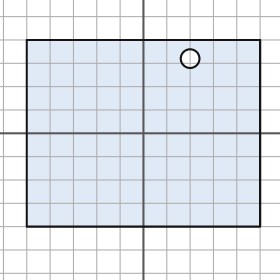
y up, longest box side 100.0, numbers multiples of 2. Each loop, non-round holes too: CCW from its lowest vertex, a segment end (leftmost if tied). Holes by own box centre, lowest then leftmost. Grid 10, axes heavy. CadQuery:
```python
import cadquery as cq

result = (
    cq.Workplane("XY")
    .moveTo(-50.0, -40.0)
    .lineTo(50.0, -40.0)
    .lineTo(50.0, 40.0)
    .lineTo(-50.0, 40.0)
    .close()
    .moveTo(20.0, 32.0)
    .circle(4.0)
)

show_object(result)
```